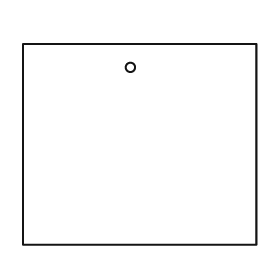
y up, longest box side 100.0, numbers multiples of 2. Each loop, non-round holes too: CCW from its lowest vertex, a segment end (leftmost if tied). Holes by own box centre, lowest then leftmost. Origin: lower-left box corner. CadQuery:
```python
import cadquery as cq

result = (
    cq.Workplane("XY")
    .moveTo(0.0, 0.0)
    .lineTo(100.0, 0.0)
    .lineTo(100.0, 86.0)
    .lineTo(0.0, 86.0)
    .close()
    .moveTo(46.0, 76.0)
    .circle(2.0)
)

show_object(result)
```